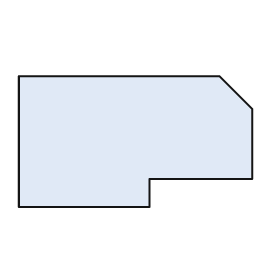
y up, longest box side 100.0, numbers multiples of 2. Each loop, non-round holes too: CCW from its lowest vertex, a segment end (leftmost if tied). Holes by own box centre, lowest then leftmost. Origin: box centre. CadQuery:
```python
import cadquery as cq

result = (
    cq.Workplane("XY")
    .moveTo(-50.0, -28.0)
    .lineTo(6.0, -28.0)
    .lineTo(6.0, -16.0)
    .lineTo(50.0, -16.0)
    .lineTo(50.0, 14.0)
    .lineTo(36.0, 28.0)
    .lineTo(-50.0, 28.0)
    .close()
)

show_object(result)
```